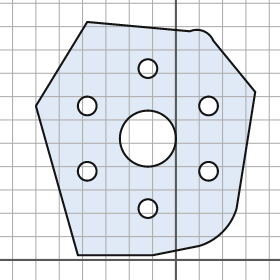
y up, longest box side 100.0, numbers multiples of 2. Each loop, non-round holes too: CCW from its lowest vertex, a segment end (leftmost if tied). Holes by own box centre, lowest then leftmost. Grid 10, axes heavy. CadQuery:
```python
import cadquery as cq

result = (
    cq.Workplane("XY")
    .moveTo(-42.0, 2.0)
    .lineTo(-10.0, 2.0)
    .lineTo(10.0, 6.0)
    .threePointArc((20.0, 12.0), (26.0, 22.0))
    .lineTo(34.0, 72.0)
    .lineTo(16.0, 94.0)
    .threePointArc((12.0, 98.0), (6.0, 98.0))
    .lineTo(-38.0, 102.0)
    .lineTo(-60.0, 66.0)
    .close()
    .moveTo(-12.0, 22.0)
    .circle(4.0)
    .moveTo(-38.0, 38.0)
    .circle(4.0)
    .moveTo(14.0, 38.0)
    .circle(4.0)
    .moveTo(-12.0, 52.0)
    .circle(12.0)
    .moveTo(-38.0, 66.0)
    .circle(4.0)
    .moveTo(14.0, 66.0)
    .circle(4.0)
    .moveTo(-12.0, 82.0)
    .circle(4.0)
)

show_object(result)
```